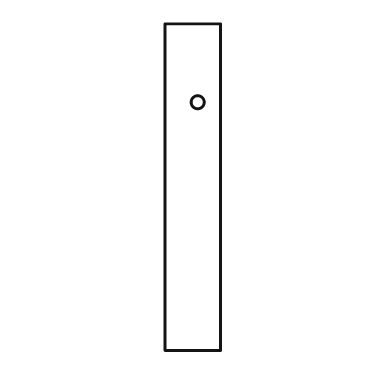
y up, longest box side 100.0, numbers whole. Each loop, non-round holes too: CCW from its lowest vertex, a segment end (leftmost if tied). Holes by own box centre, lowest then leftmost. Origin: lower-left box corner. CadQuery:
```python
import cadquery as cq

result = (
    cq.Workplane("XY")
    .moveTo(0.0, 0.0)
    .lineTo(17.0, 0.0)
    .lineTo(17.0, 100.0)
    .lineTo(0.0, 100.0)
    .close()
    .moveTo(10.0, 76.0)
    .circle(2.0)
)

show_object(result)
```